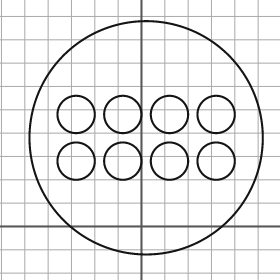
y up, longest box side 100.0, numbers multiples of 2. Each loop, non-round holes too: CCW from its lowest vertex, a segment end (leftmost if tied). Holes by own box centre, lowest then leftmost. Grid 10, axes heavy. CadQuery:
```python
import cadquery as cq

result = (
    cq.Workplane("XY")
    .moveTo(2.0, 38.0)
    .circle(50.0)
    .moveTo(-28.0, 28.0)
    .circle(8.0)
    .moveTo(-8.0, 28.0)
    .circle(8.0)
    .moveTo(12.0, 28.0)
    .circle(8.0)
    .moveTo(32.0, 28.0)
    .circle(8.0)
    .moveTo(-28.0, 48.0)
    .circle(8.0)
    .moveTo(-8.0, 48.0)
    .circle(8.0)
    .moveTo(12.0, 48.0)
    .circle(8.0)
    .moveTo(32.0, 48.0)
    .circle(8.0)
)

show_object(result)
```